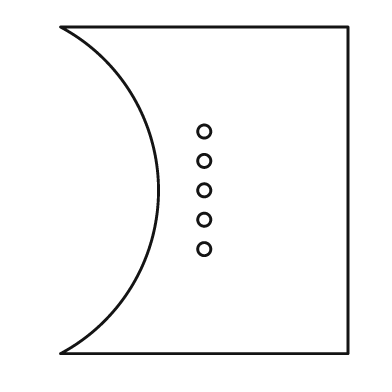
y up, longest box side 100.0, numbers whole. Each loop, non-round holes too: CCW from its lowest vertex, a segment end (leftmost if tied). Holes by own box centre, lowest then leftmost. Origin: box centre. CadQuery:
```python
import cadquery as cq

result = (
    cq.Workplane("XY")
    .moveTo(-44.0, -50.0)
    .lineTo(44.0, -50.0)
    .lineTo(44.0, 50.0)
    .lineTo(-44.0, 50.0)
    .threePointArc((-14.0, 0.0), (-44.0, -50.0))
    .close()
    .moveTo(0.0, -18.0)
    .circle(2.0)
    .moveTo(0.0, -9.0)
    .circle(2.0)
    .moveTo(0.0, 0.0)
    .circle(2.0)
    .moveTo(0.0, 9.0)
    .circle(2.0)
    .moveTo(0.0, 18.0)
    .circle(2.0)
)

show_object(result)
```